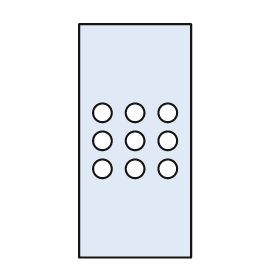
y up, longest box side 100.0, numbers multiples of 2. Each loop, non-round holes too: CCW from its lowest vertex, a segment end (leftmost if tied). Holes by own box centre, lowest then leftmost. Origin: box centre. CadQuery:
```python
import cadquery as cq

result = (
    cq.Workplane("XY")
    .moveTo(-24.0, -50.0)
    .lineTo(24.0, -50.0)
    .lineTo(24.0, 50.0)
    .lineTo(-24.0, 50.0)
    .close()
    .moveTo(-14.0, -12.0)
    .circle(4.0)
    .moveTo(0.0, -12.0)
    .circle(4.0)
    .moveTo(14.0, -12.0)
    .circle(4.0)
    .moveTo(-14.0, 0.0)
    .circle(4.0)
    .moveTo(0.0, 0.0)
    .circle(4.0)
    .moveTo(14.0, 0.0)
    .circle(4.0)
    .moveTo(-14.0, 12.0)
    .circle(4.0)
    .moveTo(0.0, 12.0)
    .circle(4.0)
    .moveTo(14.0, 12.0)
    .circle(4.0)
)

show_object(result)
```